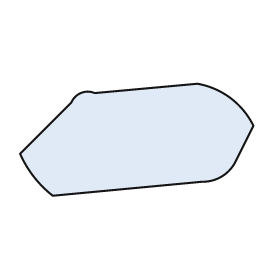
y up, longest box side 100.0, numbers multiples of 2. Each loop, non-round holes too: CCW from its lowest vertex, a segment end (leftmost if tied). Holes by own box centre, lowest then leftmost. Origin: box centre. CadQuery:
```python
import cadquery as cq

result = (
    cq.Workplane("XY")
    .moveTo(-36.0, -24.0)
    .lineTo(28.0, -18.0)
    .threePointArc((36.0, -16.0), (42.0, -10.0))
    .lineTo(50.0, 6.0)
    .threePointArc((40.0, 18.0), (26.0, 24.0))
    .lineTo(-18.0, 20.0)
    .threePointArc((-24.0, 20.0), (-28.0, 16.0))
    .lineTo(-50.0, -6.0)
    .threePointArc((-44.0, -16.0), (-36.0, -24.0))
    .close()
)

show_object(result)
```